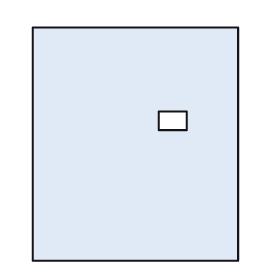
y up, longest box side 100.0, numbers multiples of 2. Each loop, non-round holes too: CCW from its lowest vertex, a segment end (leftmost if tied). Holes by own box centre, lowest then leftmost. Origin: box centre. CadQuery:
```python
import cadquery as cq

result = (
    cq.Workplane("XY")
    .moveTo(-44.0, -50.0)
    .lineTo(44.0, -50.0)
    .lineTo(44.0, 50.0)
    .lineTo(-44.0, 50.0)
    .close()
    .moveTo(10.0, 6.0)
    .lineTo(22.0, 6.0)
    .lineTo(22.0, 14.0)
    .lineTo(10.0, 14.0)
    .close()
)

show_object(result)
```